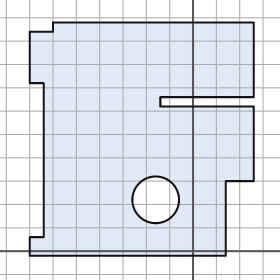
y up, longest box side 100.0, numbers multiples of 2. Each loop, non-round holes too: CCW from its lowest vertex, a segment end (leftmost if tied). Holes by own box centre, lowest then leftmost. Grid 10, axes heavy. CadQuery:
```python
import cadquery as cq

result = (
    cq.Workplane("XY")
    .moveTo(-70.0, -2.0)
    .lineTo(14.0, -2.0)
    .lineTo(14.0, 30.0)
    .lineTo(26.0, 30.0)
    .lineTo(26.0, 62.0)
    .lineTo(-14.0, 62.0)
    .lineTo(-14.0, 66.0)
    .lineTo(26.0, 66.0)
    .lineTo(26.0, 98.0)
    .lineTo(-60.0, 98.0)
    .lineTo(-60.0, 94.0)
    .lineTo(-70.0, 94.0)
    .lineTo(-70.0, 72.0)
    .lineTo(-64.0, 72.0)
    .lineTo(-64.0, 6.0)
    .lineTo(-70.0, 6.0)
    .close()
    .moveTo(-16.0, 22.0)
    .circle(10.0)
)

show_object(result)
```